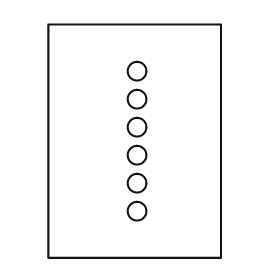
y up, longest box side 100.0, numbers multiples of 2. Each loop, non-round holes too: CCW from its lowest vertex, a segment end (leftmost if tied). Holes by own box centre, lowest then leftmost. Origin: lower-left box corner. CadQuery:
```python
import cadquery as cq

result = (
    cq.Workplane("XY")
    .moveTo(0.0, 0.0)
    .lineTo(74.0, 0.0)
    .lineTo(74.0, 100.0)
    .lineTo(0.0, 100.0)
    .close()
    .moveTo(38.0, 20.0)
    .circle(4.0)
    .moveTo(38.0, 32.0)
    .circle(4.0)
    .moveTo(38.0, 44.0)
    .circle(4.0)
    .moveTo(38.0, 56.0)
    .circle(4.0)
    .moveTo(38.0, 68.0)
    .circle(4.0)
    .moveTo(38.0, 80.0)
    .circle(4.0)
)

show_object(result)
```